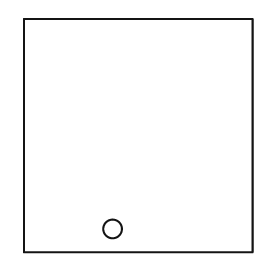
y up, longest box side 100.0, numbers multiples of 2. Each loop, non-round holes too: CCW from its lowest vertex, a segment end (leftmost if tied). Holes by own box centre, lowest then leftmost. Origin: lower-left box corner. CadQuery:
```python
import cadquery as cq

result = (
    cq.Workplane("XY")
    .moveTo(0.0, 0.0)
    .lineTo(98.0, 0.0)
    .lineTo(98.0, 100.0)
    .lineTo(0.0, 100.0)
    .close()
    .moveTo(38.0, 10.0)
    .circle(4.0)
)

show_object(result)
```